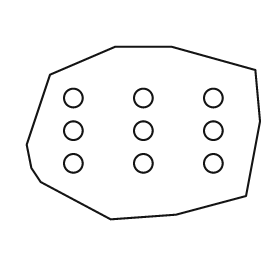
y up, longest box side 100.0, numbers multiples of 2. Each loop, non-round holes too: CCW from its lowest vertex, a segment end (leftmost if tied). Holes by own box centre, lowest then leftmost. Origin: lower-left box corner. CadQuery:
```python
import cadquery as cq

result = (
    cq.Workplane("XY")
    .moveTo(36.0, 0.0)
    .lineTo(64.0, 2.0)
    .lineTo(94.0, 10.0)
    .lineTo(100.0, 42.0)
    .lineTo(98.0, 64.0)
    .lineTo(62.0, 74.0)
    .lineTo(38.0, 74.0)
    .lineTo(10.0, 62.0)
    .lineTo(0.0, 32.0)
    .lineTo(2.0, 22.0)
    .lineTo(6.0, 16.0)
    .close()
    .moveTo(20.0, 24.0)
    .circle(4.0)
    .moveTo(50.0, 24.0)
    .circle(4.0)
    .moveTo(80.0, 24.0)
    .circle(4.0)
    .moveTo(20.0, 38.0)
    .circle(4.0)
    .moveTo(50.0, 38.0)
    .circle(4.0)
    .moveTo(80.0, 38.0)
    .circle(4.0)
    .moveTo(20.0, 52.0)
    .circle(4.0)
    .moveTo(50.0, 52.0)
    .circle(4.0)
    .moveTo(80.0, 52.0)
    .circle(4.0)
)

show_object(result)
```